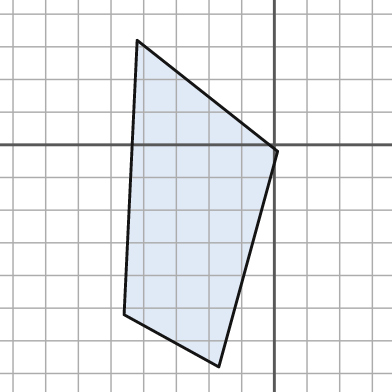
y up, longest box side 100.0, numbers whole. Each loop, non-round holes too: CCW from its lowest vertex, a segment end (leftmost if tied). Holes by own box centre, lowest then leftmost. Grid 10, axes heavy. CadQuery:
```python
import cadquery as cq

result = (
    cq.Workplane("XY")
    .moveTo(-17.0, -68.0)
    .lineTo(1.0, -2.0)
    .lineTo(-42.0, 32.0)
    .lineTo(-46.0, -52.0)
    .close()
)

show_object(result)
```